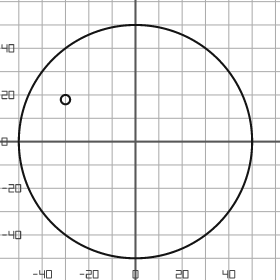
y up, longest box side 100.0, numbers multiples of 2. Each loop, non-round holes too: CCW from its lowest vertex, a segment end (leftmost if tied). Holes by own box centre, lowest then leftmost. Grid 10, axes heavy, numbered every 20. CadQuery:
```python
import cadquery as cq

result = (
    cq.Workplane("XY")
    .moveTo(0.0, 0.0)
    .circle(50.0)
    .moveTo(-30.0, 18.0)
    .circle(2.0)
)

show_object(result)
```